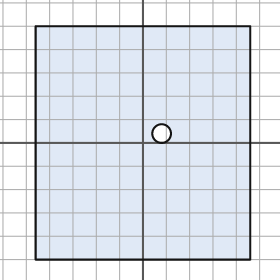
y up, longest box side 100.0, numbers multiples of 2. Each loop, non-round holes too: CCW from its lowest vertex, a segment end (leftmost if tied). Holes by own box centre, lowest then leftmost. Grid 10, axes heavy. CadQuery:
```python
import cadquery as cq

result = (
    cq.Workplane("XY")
    .moveTo(-46.0, -50.0)
    .lineTo(46.0, -50.0)
    .lineTo(46.0, 50.0)
    .lineTo(-46.0, 50.0)
    .close()
    .moveTo(8.0, 4.0)
    .circle(4.0)
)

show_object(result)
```